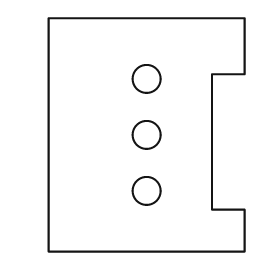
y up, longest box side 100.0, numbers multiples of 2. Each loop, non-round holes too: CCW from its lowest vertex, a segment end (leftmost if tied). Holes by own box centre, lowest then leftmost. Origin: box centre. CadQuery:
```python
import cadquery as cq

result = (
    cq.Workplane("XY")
    .moveTo(-42.0, -50.0)
    .lineTo(42.0, -50.0)
    .lineTo(42.0, -32.0)
    .lineTo(28.0, -32.0)
    .lineTo(28.0, 26.0)
    .lineTo(42.0, 26.0)
    .lineTo(42.0, 50.0)
    .lineTo(-42.0, 50.0)
    .close()
    .moveTo(0.0, -24.0)
    .circle(6.0)
    .moveTo(0.0, 0.0)
    .circle(6.0)
    .moveTo(0.0, 24.0)
    .circle(6.0)
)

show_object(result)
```